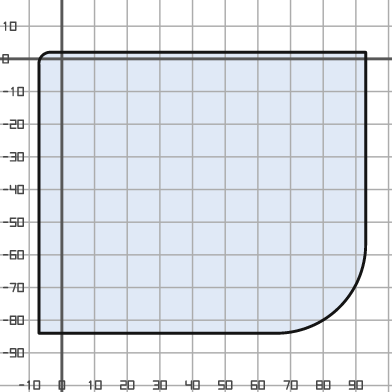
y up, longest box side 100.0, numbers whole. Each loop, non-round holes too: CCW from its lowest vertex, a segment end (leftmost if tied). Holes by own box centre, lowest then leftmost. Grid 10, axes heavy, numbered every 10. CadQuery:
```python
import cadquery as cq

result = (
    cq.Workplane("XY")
    .moveTo(-7.0, -84.0)
    .lineTo(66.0, -84.0)
    .threePointArc((85.0, -76.0), (93.0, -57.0))
    .lineTo(93.0, 2.0)
    .lineTo(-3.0, 2.0)
    .threePointArc((-6.0, 1.0), (-7.0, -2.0))
    .close()
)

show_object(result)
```